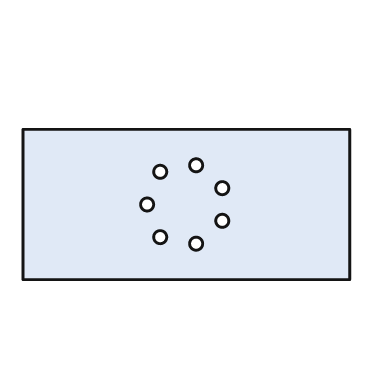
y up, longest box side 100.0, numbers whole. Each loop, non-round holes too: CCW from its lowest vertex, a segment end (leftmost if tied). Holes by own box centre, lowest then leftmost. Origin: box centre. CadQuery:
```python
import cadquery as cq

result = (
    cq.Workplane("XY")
    .moveTo(-50.0, -23.0)
    .lineTo(50.0, -23.0)
    .lineTo(50.0, 23.0)
    .lineTo(-50.0, 23.0)
    .close()
    .moveTo(3.0, -12.0)
    .circle(2.0)
    .moveTo(-8.0, -10.0)
    .circle(2.0)
    .moveTo(11.0, -5.0)
    .circle(2.0)
    .moveTo(-12.0, 0.0)
    .circle(2.0)
    .moveTo(11.0, 5.0)
    .circle(2.0)
    .moveTo(-8.0, 10.0)
    .circle(2.0)
    .moveTo(3.0, 12.0)
    .circle(2.0)
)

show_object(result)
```